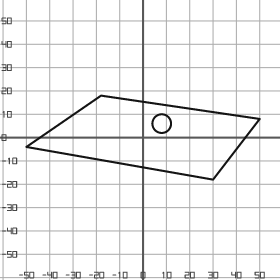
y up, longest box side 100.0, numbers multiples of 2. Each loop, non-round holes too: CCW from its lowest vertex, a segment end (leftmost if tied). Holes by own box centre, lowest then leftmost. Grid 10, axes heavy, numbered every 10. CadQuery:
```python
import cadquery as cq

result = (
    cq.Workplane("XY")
    .moveTo(30.0, -18.0)
    .lineTo(50.0, 8.0)
    .lineTo(-18.0, 18.0)
    .lineTo(-50.0, -4.0)
    .close()
    .moveTo(8.0, 6.0)
    .circle(4.0)
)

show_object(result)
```